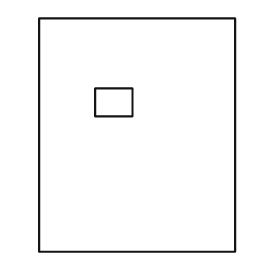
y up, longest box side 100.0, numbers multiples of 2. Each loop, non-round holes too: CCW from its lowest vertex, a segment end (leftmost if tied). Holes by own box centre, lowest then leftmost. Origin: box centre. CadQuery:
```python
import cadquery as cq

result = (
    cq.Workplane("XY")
    .moveTo(-42.0, -50.0)
    .lineTo(42.0, -50.0)
    .lineTo(42.0, 50.0)
    .lineTo(-42.0, 50.0)
    .close()
    .moveTo(-18.0, 8.0)
    .lineTo(-2.0, 8.0)
    .lineTo(-2.0, 20.0)
    .lineTo(-18.0, 20.0)
    .close()
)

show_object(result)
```